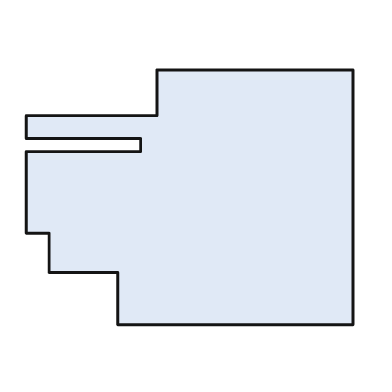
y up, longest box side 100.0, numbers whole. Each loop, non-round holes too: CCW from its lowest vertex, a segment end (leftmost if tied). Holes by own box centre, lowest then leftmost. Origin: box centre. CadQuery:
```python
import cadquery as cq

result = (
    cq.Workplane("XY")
    .moveTo(-22.0, -39.0)
    .lineTo(50.0, -39.0)
    .lineTo(50.0, 39.0)
    .lineTo(-10.0, 39.0)
    .lineTo(-10.0, 25.0)
    .lineTo(-50.0, 25.0)
    .lineTo(-50.0, 18.0)
    .lineTo(-15.0, 18.0)
    .lineTo(-15.0, 14.0)
    .lineTo(-50.0, 14.0)
    .lineTo(-50.0, -11.0)
    .lineTo(-43.0, -11.0)
    .lineTo(-43.0, -23.0)
    .lineTo(-22.0, -23.0)
    .close()
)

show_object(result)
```